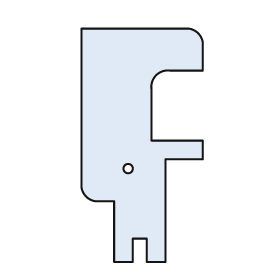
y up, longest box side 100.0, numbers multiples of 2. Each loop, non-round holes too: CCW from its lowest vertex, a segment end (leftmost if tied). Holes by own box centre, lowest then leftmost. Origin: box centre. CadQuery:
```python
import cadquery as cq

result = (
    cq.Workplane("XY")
    .moveTo(-12.0, -50.0)
    .lineTo(-4.0, -50.0)
    .lineTo(-4.0, -40.0)
    .lineTo(2.0, -40.0)
    .lineTo(2.0, -50.0)
    .lineTo(10.0, -50.0)
    .lineTo(10.0, -6.0)
    .lineTo(26.0, -6.0)
    .lineTo(26.0, 2.0)
    .lineTo(4.0, 2.0)
    .lineTo(4.0, 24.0)
    .threePointArc((6.0, 30.0), (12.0, 32.0))
    .lineTo(26.0, 32.0)
    .lineTo(26.0, 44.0)
    .threePointArc((24.0, 48.0), (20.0, 50.0))
    .lineTo(-26.0, 50.0)
    .lineTo(-26.0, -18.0)
    .threePointArc((-24.0, -22.0), (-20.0, -24.0))
    .lineTo(-12.0, -24.0)
    .close()
    .moveTo(-6.0, -10.0)
    .circle(2.0)
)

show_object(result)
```